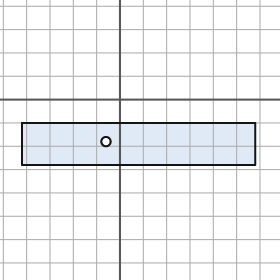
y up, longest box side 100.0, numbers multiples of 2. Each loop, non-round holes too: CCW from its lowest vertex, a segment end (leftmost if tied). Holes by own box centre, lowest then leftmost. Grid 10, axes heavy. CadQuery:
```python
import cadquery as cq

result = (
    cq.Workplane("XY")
    .moveTo(-42.0, -28.0)
    .lineTo(58.0, -28.0)
    .lineTo(58.0, -10.0)
    .lineTo(-42.0, -10.0)
    .close()
    .moveTo(-6.0, -18.0)
    .circle(2.0)
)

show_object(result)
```